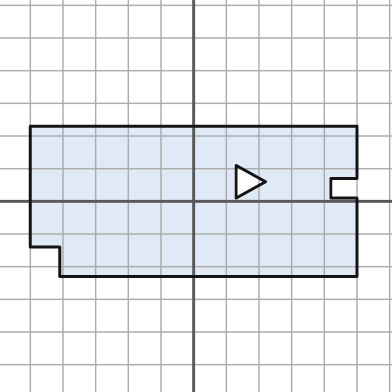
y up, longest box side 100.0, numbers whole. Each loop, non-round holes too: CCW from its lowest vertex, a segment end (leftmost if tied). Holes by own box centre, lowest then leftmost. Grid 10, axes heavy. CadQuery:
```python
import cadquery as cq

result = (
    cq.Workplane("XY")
    .moveTo(-41.0, -23.0)
    .lineTo(50.0, -23.0)
    .lineTo(50.0, 1.0)
    .lineTo(42.0, 1.0)
    .lineTo(42.0, 7.0)
    .lineTo(50.0, 7.0)
    .lineTo(50.0, 23.0)
    .lineTo(-50.0, 23.0)
    .lineTo(-50.0, -14.0)
    .lineTo(-41.0, -14.0)
    .close()
    .moveTo(13.0, 1.0)
    .lineTo(22.0, 6.0)
    .lineTo(13.0, 11.0)
    .close()
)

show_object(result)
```